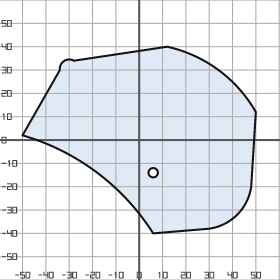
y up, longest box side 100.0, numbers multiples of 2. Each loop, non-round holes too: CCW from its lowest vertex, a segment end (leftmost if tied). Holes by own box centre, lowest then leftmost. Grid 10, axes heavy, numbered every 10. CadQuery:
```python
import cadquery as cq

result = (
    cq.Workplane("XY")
    .moveTo(6.0, -40.0)
    .lineTo(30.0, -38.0)
    .threePointArc((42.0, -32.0), (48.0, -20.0))
    .lineTo(50.0, 12.0)
    .threePointArc((34.0, 30.0), (12.0, 40.0))
    .lineTo(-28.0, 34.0)
    .threePointArc((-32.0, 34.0), (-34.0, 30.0))
    .lineTo(-50.0, 2.0)
    .threePointArc((-18.0, -14.0), (6.0, -40.0))
    .close()
    .moveTo(6.0, -14.0)
    .circle(2.0)
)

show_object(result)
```